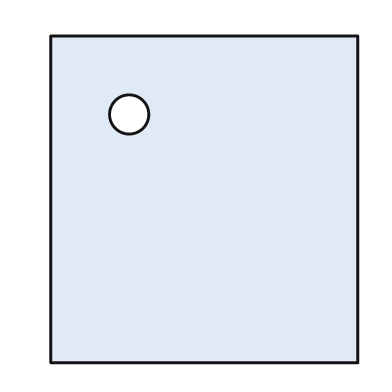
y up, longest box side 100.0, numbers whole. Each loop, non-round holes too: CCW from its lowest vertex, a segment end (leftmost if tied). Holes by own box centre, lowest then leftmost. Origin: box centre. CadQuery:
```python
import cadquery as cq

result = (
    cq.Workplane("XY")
    .moveTo(-47.0, -50.0)
    .lineTo(47.0, -50.0)
    .lineTo(47.0, 50.0)
    .lineTo(-47.0, 50.0)
    .close()
    .moveTo(-23.0, 26.0)
    .circle(6.0)
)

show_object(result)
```